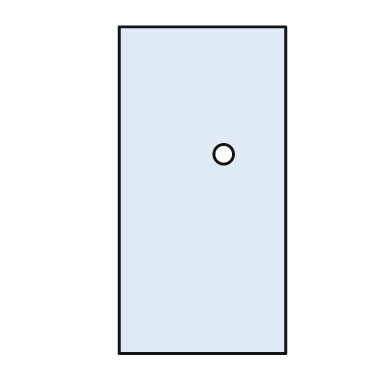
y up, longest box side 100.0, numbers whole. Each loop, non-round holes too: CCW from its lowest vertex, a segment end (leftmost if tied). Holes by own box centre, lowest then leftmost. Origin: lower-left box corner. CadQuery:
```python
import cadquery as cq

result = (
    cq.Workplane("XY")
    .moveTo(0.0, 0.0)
    .lineTo(51.0, 0.0)
    .lineTo(51.0, 100.0)
    .lineTo(0.0, 100.0)
    .close()
    .moveTo(32.0, 61.0)
    .circle(3.0)
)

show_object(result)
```